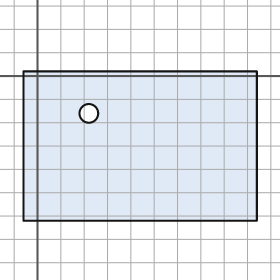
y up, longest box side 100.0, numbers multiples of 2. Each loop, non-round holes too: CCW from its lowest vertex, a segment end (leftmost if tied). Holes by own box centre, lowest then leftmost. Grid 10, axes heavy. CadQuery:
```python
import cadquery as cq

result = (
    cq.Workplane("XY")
    .moveTo(-6.0, -62.0)
    .lineTo(94.0, -62.0)
    .lineTo(94.0, 2.0)
    .lineTo(-6.0, 2.0)
    .close()
    .moveTo(22.0, -16.0)
    .circle(4.0)
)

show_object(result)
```